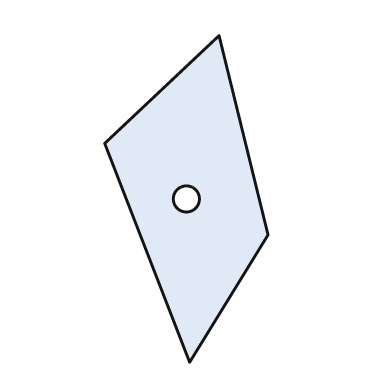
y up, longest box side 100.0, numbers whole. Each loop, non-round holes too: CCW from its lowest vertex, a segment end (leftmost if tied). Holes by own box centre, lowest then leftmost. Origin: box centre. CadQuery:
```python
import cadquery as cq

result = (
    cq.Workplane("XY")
    .moveTo(1.0, -50.0)
    .lineTo(25.0, -11.0)
    .lineTo(10.0, 50.0)
    .lineTo(-25.0, 17.0)
    .close()
    .moveTo(0.0, 0.0)
    .circle(4.0)
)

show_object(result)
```